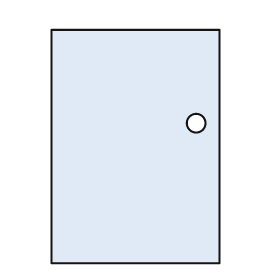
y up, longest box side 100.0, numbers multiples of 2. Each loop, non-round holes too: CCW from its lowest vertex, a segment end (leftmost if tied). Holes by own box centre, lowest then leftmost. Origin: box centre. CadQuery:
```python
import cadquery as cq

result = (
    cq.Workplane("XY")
    .moveTo(-36.0, -50.0)
    .lineTo(36.0, -50.0)
    .lineTo(36.0, 50.0)
    .lineTo(-36.0, 50.0)
    .close()
    .moveTo(26.0, 10.0)
    .circle(4.0)
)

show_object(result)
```